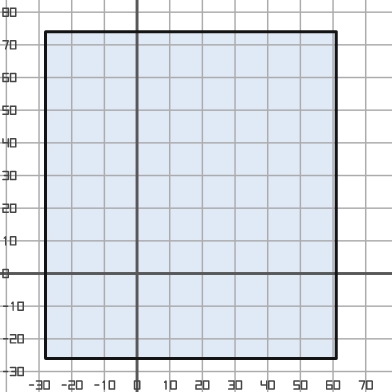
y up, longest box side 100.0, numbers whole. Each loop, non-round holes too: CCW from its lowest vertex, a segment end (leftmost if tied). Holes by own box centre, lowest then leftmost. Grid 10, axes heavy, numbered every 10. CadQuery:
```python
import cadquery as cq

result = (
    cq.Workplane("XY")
    .moveTo(-28.0, -26.0)
    .lineTo(61.0, -26.0)
    .lineTo(61.0, 74.0)
    .lineTo(-28.0, 74.0)
    .close()
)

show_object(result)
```